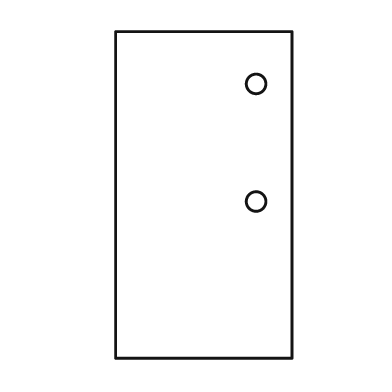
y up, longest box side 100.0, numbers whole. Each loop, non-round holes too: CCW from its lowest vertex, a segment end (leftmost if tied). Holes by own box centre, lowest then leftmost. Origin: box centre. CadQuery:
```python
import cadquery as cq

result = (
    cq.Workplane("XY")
    .moveTo(-27.0, -50.0)
    .lineTo(27.0, -50.0)
    .lineTo(27.0, 50.0)
    .lineTo(-27.0, 50.0)
    .close()
    .moveTo(16.0, -2.0)
    .circle(3.0)
    .moveTo(16.0, 34.0)
    .circle(3.0)
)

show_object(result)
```